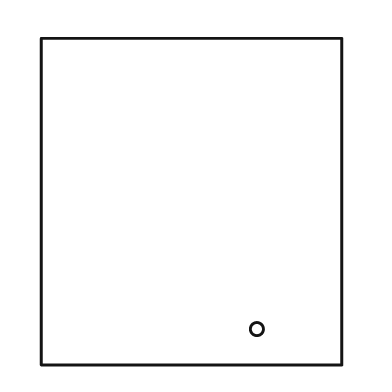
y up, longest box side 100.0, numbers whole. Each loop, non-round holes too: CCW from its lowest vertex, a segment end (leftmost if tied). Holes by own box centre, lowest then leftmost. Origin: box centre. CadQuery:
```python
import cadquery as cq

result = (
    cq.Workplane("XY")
    .moveTo(-46.0, -50.0)
    .lineTo(46.0, -50.0)
    .lineTo(46.0, 50.0)
    .lineTo(-46.0, 50.0)
    .close()
    .moveTo(20.0, -39.0)
    .circle(2.0)
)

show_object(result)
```